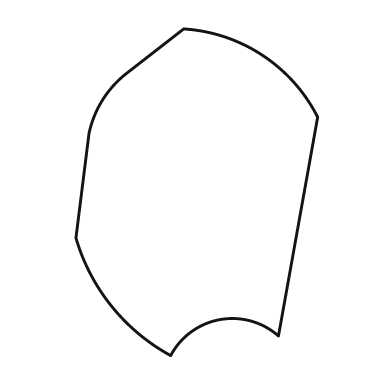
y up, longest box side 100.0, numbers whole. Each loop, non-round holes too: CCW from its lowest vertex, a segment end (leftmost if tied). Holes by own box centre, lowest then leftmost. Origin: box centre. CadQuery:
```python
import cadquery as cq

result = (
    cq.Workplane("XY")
    .moveTo(-8.0, -50.0)
    .threePointArc((7.0, -39.0), (25.0, -44.0))
    .lineTo(37.0, 23.0)
    .threePointArc((20.0, 42.0), (-4.0, 50.0))
    .lineTo(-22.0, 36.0)
    .threePointArc((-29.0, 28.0), (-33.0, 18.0))
    .lineTo(-37.0, -14.0)
    .threePointArc((-26.0, -35.0), (-8.0, -50.0))
    .close()
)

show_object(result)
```